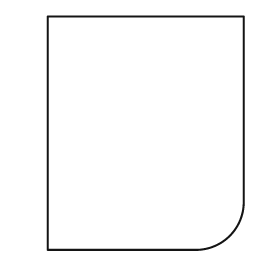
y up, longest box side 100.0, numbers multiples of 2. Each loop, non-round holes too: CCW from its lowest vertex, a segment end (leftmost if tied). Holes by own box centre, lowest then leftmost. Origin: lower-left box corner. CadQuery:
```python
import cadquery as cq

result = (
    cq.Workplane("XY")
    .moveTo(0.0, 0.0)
    .lineTo(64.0, 0.0)
    .threePointArc((78.0, 6.0), (84.0, 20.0))
    .lineTo(84.0, 100.0)
    .lineTo(0.0, 100.0)
    .close()
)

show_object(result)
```